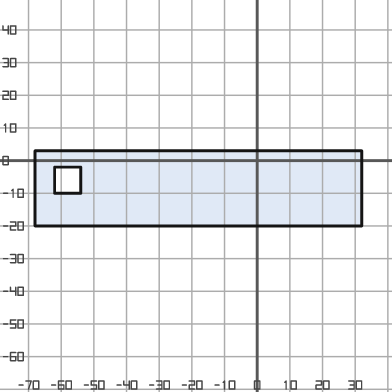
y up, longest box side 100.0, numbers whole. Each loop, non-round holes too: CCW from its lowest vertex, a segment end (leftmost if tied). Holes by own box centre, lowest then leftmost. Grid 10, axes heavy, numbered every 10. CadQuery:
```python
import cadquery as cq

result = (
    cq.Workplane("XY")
    .moveTo(-68.0, -20.0)
    .lineTo(32.0, -20.0)
    .lineTo(32.0, 3.0)
    .lineTo(-68.0, 3.0)
    .close()
    .moveTo(-62.0, -10.0)
    .lineTo(-54.0, -10.0)
    .lineTo(-54.0, -2.0)
    .lineTo(-62.0, -2.0)
    .close()
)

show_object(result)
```